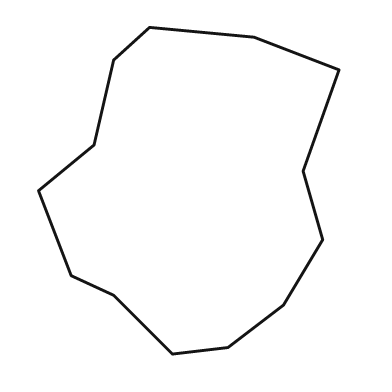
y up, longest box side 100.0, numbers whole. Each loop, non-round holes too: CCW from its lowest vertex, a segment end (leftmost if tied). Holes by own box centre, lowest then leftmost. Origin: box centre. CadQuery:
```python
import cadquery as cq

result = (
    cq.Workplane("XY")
    .moveTo(-5.0, -50.0)
    .lineTo(12.0, -48.0)
    .lineTo(29.0, -35.0)
    .lineTo(41.0, -15.0)
    .lineTo(35.0, 6.0)
    .lineTo(46.0, 37.0)
    .lineTo(20.0, 47.0)
    .lineTo(-12.0, 50.0)
    .lineTo(-23.0, 40.0)
    .lineTo(-29.0, 14.0)
    .lineTo(-46.0, 0.0)
    .lineTo(-36.0, -26.0)
    .lineTo(-23.0, -32.0)
    .close()
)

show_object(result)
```